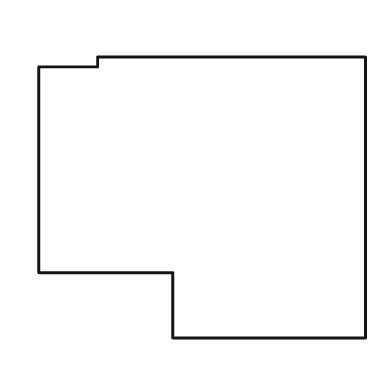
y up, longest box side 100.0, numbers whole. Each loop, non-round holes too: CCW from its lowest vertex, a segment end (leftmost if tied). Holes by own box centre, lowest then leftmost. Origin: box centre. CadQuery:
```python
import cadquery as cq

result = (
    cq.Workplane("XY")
    .moveTo(-9.0, -43.0)
    .lineTo(50.0, -43.0)
    .lineTo(50.0, 43.0)
    .lineTo(-32.0, 43.0)
    .lineTo(-32.0, 40.0)
    .lineTo(-50.0, 40.0)
    .lineTo(-50.0, -23.0)
    .lineTo(-9.0, -23.0)
    .close()
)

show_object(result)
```